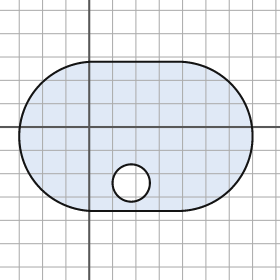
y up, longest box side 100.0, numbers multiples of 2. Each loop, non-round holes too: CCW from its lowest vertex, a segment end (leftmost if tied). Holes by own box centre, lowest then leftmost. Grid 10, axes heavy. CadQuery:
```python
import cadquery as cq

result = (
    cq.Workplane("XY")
    .moveTo(2.0, -36.0)
    .lineTo(38.0, -36.0)
    .threePointArc((70.0, -4.0), (38.0, 28.0))
    .lineTo(2.0, 28.0)
    .threePointArc((-30.0, -4.0), (2.0, -36.0))
    .close()
    .moveTo(18.0, -24.0)
    .circle(8.0)
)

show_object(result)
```